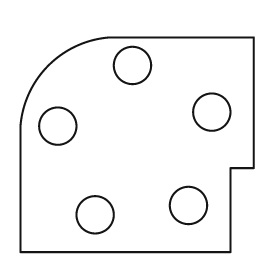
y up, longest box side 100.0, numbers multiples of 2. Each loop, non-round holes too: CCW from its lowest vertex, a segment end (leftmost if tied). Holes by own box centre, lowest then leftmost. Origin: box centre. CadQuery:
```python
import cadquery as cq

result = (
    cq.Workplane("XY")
    .moveTo(-50.0, -46.0)
    .lineTo(40.0, -46.0)
    .lineTo(40.0, -10.0)
    .lineTo(50.0, -10.0)
    .lineTo(50.0, 46.0)
    .lineTo(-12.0, 46.0)
    .threePointArc((-38.0, 34.0), (-50.0, 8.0))
    .close()
    .moveTo(-18.0, -30.0)
    .circle(8.0)
    .moveTo(22.0, -26.0)
    .circle(8.0)
    .moveTo(-34.0, 8.0)
    .circle(8.0)
    .moveTo(32.0, 14.0)
    .circle(8.0)
    .moveTo(-2.0, 34.0)
    .circle(8.0)
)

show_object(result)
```